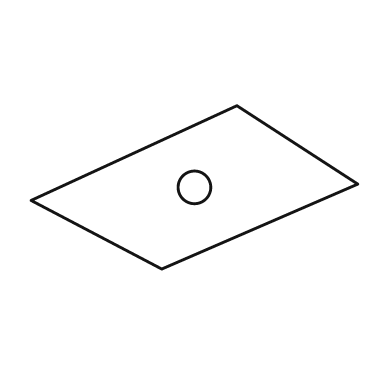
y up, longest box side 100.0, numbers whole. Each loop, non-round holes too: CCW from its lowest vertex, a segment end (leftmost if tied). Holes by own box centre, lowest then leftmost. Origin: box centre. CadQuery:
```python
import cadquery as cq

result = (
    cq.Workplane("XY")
    .moveTo(-10.0, -25.0)
    .lineTo(50.0, 1.0)
    .lineTo(13.0, 25.0)
    .lineTo(-50.0, -4.0)
    .close()
    .moveTo(0.0, 0.0)
    .circle(5.0)
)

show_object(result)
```